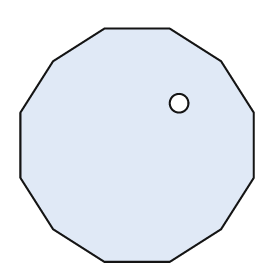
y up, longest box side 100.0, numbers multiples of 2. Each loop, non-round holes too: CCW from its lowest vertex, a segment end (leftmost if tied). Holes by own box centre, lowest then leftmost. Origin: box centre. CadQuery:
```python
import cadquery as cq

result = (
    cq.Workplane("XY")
    .moveTo(-14.0, -50.0)
    .lineTo(14.0, -50.0)
    .lineTo(36.0, -36.0)
    .lineTo(50.0, -14.0)
    .lineTo(50.0, 14.0)
    .lineTo(36.0, 36.0)
    .lineTo(14.0, 50.0)
    .lineTo(-14.0, 50.0)
    .lineTo(-36.0, 36.0)
    .lineTo(-50.0, 14.0)
    .lineTo(-50.0, -14.0)
    .lineTo(-36.0, -36.0)
    .close()
    .moveTo(18.0, 18.0)
    .circle(4.0)
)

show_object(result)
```